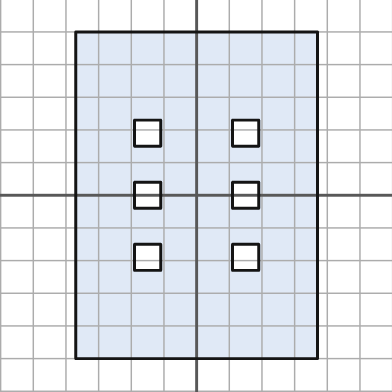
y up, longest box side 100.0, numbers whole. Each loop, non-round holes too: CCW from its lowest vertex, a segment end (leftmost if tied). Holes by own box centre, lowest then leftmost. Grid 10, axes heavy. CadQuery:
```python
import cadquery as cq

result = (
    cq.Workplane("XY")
    .moveTo(-37.0, -50.0)
    .lineTo(37.0, -50.0)
    .lineTo(37.0, 50.0)
    .lineTo(-37.0, 50.0)
    .close()
    .moveTo(-19.0, -23.0)
    .lineTo(-11.0, -23.0)
    .lineTo(-11.0, -15.0)
    .lineTo(-19.0, -15.0)
    .close()
    .moveTo(11.0, -23.0)
    .lineTo(19.0, -23.0)
    .lineTo(19.0, -15.0)
    .lineTo(11.0, -15.0)
    .close()
    .moveTo(-19.0, -4.0)
    .lineTo(-11.0, -4.0)
    .lineTo(-11.0, 4.0)
    .lineTo(-19.0, 4.0)
    .close()
    .moveTo(11.0, -4.0)
    .lineTo(19.0, -4.0)
    .lineTo(19.0, 4.0)
    .lineTo(11.0, 4.0)
    .close()
    .moveTo(-19.0, 15.0)
    .lineTo(-11.0, 15.0)
    .lineTo(-11.0, 23.0)
    .lineTo(-19.0, 23.0)
    .close()
    .moveTo(11.0, 15.0)
    .lineTo(19.0, 15.0)
    .lineTo(19.0, 23.0)
    .lineTo(11.0, 23.0)
    .close()
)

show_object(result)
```